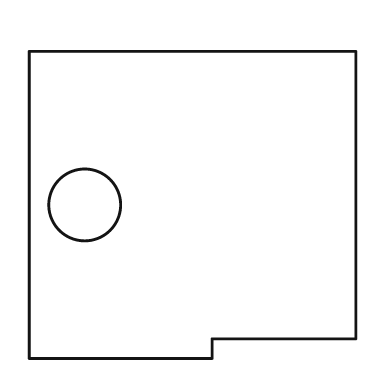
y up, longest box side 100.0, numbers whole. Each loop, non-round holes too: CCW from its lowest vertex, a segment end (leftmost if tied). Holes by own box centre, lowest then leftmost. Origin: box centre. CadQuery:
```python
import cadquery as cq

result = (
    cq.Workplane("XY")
    .moveTo(-50.0, -47.0)
    .lineTo(6.0, -47.0)
    .lineTo(6.0, -41.0)
    .lineTo(50.0, -41.0)
    .lineTo(50.0, 47.0)
    .lineTo(-50.0, 47.0)
    .close()
    .moveTo(-33.0, 0.0)
    .circle(11.0)
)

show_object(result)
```